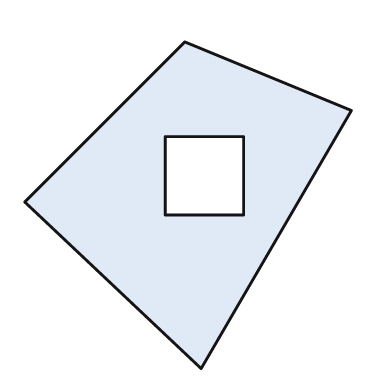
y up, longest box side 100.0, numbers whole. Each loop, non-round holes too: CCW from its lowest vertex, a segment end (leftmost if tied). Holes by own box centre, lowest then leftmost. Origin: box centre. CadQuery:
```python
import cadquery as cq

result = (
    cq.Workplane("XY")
    .moveTo(4.0, -50.0)
    .lineTo(50.0, 29.0)
    .lineTo(-1.0, 50.0)
    .lineTo(-50.0, 1.0)
    .close()
    .moveTo(-7.0, -3.0)
    .lineTo(17.0, -3.0)
    .lineTo(17.0, 21.0)
    .lineTo(-7.0, 21.0)
    .close()
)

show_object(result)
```